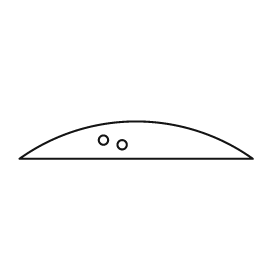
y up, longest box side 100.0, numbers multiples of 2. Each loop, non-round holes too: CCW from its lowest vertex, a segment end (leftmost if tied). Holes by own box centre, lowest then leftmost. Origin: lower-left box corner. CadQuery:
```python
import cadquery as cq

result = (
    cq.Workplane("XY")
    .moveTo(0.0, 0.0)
    .lineTo(100.0, 0.0)
    .threePointArc((50.0, 16.0), (0.0, 0.0))
    .close()
    .moveTo(44.0, 6.0)
    .circle(2.0)
    .moveTo(36.0, 8.0)
    .circle(2.0)
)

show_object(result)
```